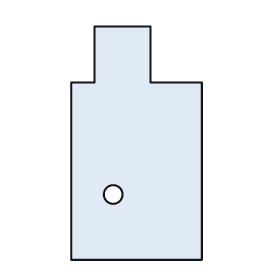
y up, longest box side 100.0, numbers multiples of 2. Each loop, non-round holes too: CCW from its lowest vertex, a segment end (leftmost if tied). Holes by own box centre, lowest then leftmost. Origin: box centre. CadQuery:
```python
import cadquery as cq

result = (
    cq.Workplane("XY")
    .moveTo(-28.0, -50.0)
    .lineTo(28.0, -50.0)
    .lineTo(28.0, 26.0)
    .lineTo(6.0, 26.0)
    .lineTo(6.0, 50.0)
    .lineTo(-18.0, 50.0)
    .lineTo(-18.0, 26.0)
    .lineTo(-28.0, 26.0)
    .close()
    .moveTo(-10.0, -22.0)
    .circle(4.0)
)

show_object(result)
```